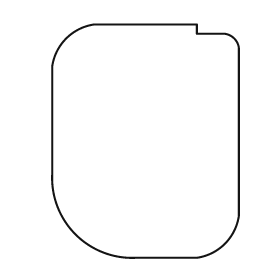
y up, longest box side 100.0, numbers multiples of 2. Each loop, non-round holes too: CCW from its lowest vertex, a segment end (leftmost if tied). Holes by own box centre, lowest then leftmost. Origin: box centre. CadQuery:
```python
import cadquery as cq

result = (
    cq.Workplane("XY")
    .moveTo(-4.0, -50.0)
    .lineTo(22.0, -50.0)
    .threePointArc((34.0, -44.0), (40.0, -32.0))
    .lineTo(40.0, 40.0)
    .threePointArc((38.0, 44.0), (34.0, 46.0))
    .lineTo(22.0, 46.0)
    .lineTo(22.0, 50.0)
    .lineTo(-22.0, 50.0)
    .threePointArc((-34.0, 44.0), (-40.0, 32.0))
    .lineTo(-40.0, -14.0)
    .threePointArc((-30.0, -40.0), (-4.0, -50.0))
    .close()
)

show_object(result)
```